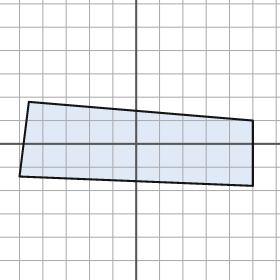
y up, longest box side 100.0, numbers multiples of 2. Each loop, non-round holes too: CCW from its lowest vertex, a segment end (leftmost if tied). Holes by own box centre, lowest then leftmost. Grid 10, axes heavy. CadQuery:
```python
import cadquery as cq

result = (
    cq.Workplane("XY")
    .moveTo(50.0, -18.0)
    .lineTo(50.0, 10.0)
    .lineTo(-46.0, 18.0)
    .lineTo(-50.0, -14.0)
    .close()
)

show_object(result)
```